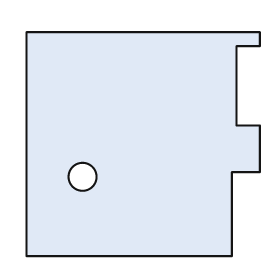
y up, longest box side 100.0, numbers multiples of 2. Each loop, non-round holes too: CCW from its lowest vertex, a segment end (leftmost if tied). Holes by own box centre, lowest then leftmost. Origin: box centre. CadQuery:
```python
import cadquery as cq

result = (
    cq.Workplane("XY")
    .moveTo(-50.0, -48.0)
    .lineTo(38.0, -48.0)
    .lineTo(38.0, -12.0)
    .lineTo(50.0, -12.0)
    .lineTo(50.0, 8.0)
    .lineTo(40.0, 8.0)
    .lineTo(40.0, 42.0)
    .lineTo(50.0, 42.0)
    .lineTo(50.0, 48.0)
    .lineTo(-50.0, 48.0)
    .close()
    .moveTo(-26.0, -14.0)
    .circle(6.0)
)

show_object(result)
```